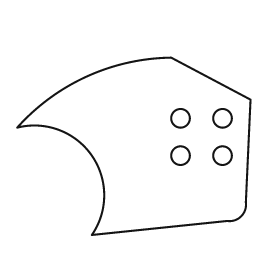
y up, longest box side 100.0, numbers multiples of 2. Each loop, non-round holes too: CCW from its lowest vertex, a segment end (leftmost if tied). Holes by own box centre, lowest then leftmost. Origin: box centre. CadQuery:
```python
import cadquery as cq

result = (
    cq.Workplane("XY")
    .moveTo(-18.0, -38.0)
    .lineTo(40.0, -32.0)
    .threePointArc((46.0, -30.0), (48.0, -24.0))
    .lineTo(50.0, 20.0)
    .lineTo(16.0, 38.0)
    .threePointArc((-20.0, 30.0), (-50.0, 8.0))
    .threePointArc((-18.0, -4.0), (-18.0, -38.0))
    .close()
    .moveTo(20.0, -4.0)
    .circle(4.0)
    .moveTo(38.0, -4.0)
    .circle(4.0)
    .moveTo(20.0, 12.0)
    .circle(4.0)
    .moveTo(38.0, 12.0)
    .circle(4.0)
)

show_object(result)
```